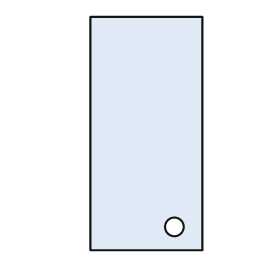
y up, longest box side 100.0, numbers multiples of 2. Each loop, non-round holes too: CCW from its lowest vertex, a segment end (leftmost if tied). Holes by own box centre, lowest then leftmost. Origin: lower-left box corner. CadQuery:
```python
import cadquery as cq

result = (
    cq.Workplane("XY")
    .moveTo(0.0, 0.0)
    .lineTo(48.0, 0.0)
    .lineTo(48.0, 100.0)
    .lineTo(0.0, 100.0)
    .close()
    .moveTo(36.0, 10.0)
    .circle(4.0)
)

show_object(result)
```